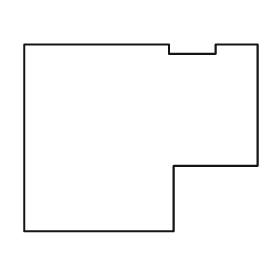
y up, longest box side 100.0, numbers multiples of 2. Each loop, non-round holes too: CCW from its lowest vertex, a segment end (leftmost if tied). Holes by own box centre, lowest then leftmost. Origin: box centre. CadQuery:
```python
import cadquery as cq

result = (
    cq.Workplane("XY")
    .moveTo(-50.0, -40.0)
    .lineTo(14.0, -40.0)
    .lineTo(14.0, -12.0)
    .lineTo(50.0, -12.0)
    .lineTo(50.0, 40.0)
    .lineTo(32.0, 40.0)
    .lineTo(32.0, 36.0)
    .lineTo(12.0, 36.0)
    .lineTo(12.0, 40.0)
    .lineTo(-50.0, 40.0)
    .close()
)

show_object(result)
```